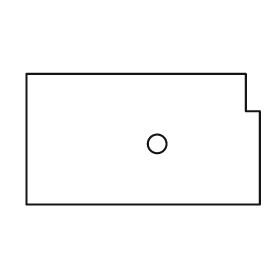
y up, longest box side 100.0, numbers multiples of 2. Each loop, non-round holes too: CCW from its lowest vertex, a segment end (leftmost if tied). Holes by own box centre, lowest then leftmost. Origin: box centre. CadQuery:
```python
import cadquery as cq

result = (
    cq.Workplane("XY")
    .moveTo(-50.0, -28.0)
    .lineTo(50.0, -28.0)
    .lineTo(50.0, 12.0)
    .lineTo(44.0, 12.0)
    .lineTo(44.0, 28.0)
    .lineTo(-50.0, 28.0)
    .close()
    .moveTo(6.0, -2.0)
    .circle(4.0)
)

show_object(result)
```